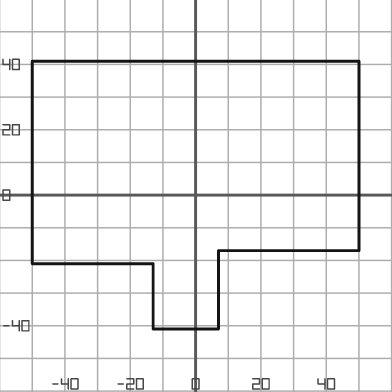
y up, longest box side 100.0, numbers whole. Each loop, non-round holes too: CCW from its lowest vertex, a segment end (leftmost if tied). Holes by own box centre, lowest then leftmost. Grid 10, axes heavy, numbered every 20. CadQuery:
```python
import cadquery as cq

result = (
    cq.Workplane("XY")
    .moveTo(-13.0, -41.0)
    .lineTo(7.0, -41.0)
    .lineTo(7.0, -17.0)
    .lineTo(50.0, -17.0)
    .lineTo(50.0, 41.0)
    .lineTo(-50.0, 41.0)
    .lineTo(-50.0, -21.0)
    .lineTo(-13.0, -21.0)
    .close()
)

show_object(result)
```